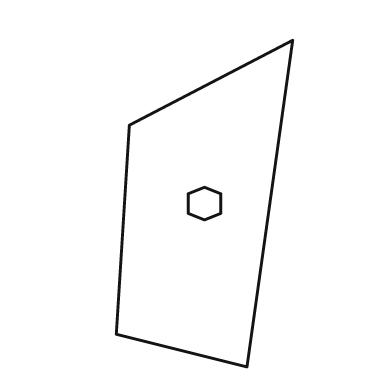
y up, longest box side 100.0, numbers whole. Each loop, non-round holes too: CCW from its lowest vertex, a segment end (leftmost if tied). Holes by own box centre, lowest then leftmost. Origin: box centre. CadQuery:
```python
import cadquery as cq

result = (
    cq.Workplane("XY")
    .moveTo(13.0, -50.0)
    .lineTo(27.0, 50.0)
    .lineTo(-23.0, 24.0)
    .lineTo(-27.0, -40.0)
    .close()
    .moveTo(0.0, -5.0)
    .lineTo(5.0, -3.0)
    .lineTo(5.0, 3.0)
    .lineTo(0.0, 5.0)
    .lineTo(-5.0, 3.0)
    .lineTo(-5.0, -3.0)
    .close()
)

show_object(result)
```